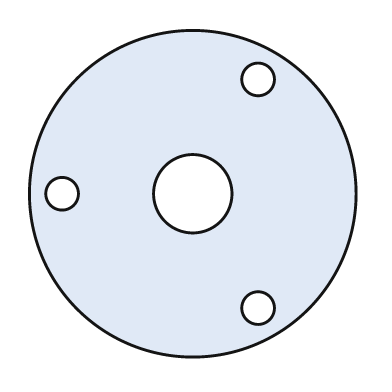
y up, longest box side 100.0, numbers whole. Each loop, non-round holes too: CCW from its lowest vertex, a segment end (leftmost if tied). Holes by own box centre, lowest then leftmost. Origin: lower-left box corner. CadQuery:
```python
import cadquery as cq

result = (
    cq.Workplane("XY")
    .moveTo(50.0, 50.0)
    .circle(50.0)
    .moveTo(70.0, 15.0)
    .circle(5.0)
    .moveTo(10.0, 50.0)
    .circle(5.0)
    .moveTo(50.0, 50.0)
    .circle(12.0)
    .moveTo(70.0, 85.0)
    .circle(5.0)
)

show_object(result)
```